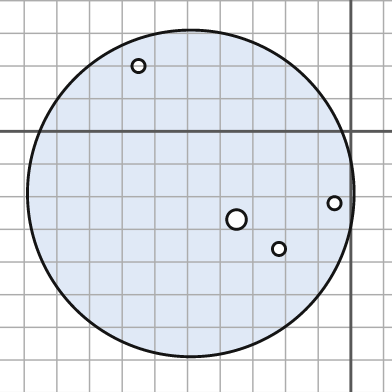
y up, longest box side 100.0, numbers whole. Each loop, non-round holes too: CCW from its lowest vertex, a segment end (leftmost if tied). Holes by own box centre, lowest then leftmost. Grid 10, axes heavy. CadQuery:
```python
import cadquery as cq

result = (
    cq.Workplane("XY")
    .moveTo(-49.0, -19.0)
    .circle(50.0)
    .moveTo(-22.0, -36.0)
    .circle(2.0)
    .moveTo(-35.0, -27.0)
    .circle(3.0)
    .moveTo(-5.0, -22.0)
    .circle(2.0)
    .moveTo(-65.0, 20.0)
    .circle(2.0)
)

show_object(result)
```